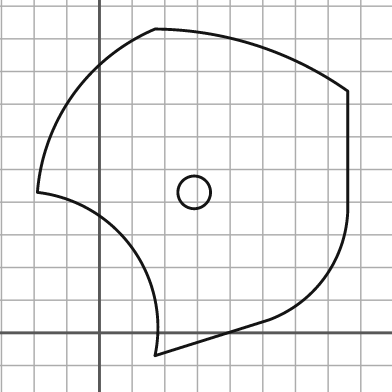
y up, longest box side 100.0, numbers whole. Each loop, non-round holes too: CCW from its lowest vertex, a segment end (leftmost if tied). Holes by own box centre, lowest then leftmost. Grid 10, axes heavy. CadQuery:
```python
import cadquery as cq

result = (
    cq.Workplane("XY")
    .moveTo(17.0, -7.0)
    .lineTo(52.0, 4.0)
    .threePointArc((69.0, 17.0), (76.0, 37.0))
    .lineTo(76.0, 74.0)
    .threePointArc((48.0, 88.0), (17.0, 93.0))
    .threePointArc((-8.0, 73.0), (-19.0, 43.0))
    .threePointArc((10.0, 26.0), (17.0, -7.0))
    .close()
    .moveTo(29.0, 43.0)
    .circle(5.0)
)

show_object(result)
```